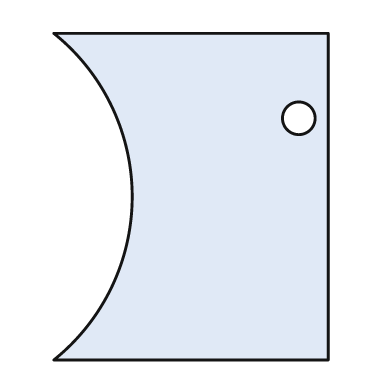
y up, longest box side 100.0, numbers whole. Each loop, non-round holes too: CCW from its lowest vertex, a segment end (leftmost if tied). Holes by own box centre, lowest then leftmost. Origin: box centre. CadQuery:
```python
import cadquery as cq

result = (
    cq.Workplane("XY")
    .moveTo(-42.0, -50.0)
    .lineTo(42.0, -50.0)
    .lineTo(42.0, 50.0)
    .lineTo(-42.0, 50.0)
    .threePointArc((-18.0, 0.0), (-42.0, -50.0))
    .close()
    .moveTo(33.0, 24.0)
    .circle(5.0)
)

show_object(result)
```